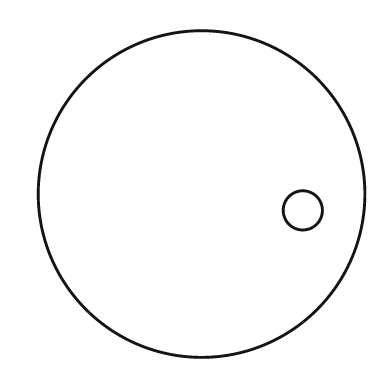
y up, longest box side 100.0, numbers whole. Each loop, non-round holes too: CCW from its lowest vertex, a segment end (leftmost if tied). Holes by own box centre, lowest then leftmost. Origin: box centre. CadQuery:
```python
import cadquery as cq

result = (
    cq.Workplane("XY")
    .moveTo(0.0, 0.0)
    .circle(50.0)
    .moveTo(31.0, -5.0)
    .circle(6.0)
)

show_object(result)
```